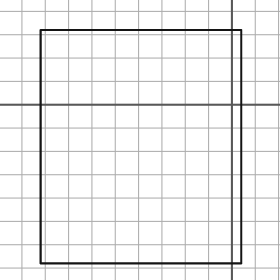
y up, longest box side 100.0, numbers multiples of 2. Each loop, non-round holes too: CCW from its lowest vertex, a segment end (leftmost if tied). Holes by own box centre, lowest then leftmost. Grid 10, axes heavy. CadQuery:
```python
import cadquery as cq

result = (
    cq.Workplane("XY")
    .moveTo(-82.0, -68.0)
    .lineTo(4.0, -68.0)
    .lineTo(4.0, 32.0)
    .lineTo(-82.0, 32.0)
    .close()
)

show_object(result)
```